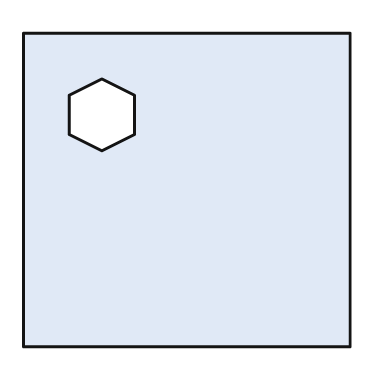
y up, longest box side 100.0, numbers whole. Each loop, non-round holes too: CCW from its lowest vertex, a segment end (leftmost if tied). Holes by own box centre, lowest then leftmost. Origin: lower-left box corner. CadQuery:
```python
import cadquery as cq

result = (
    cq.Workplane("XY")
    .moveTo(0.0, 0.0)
    .lineTo(100.0, 0.0)
    .lineTo(100.0, 96.0)
    .lineTo(0.0, 96.0)
    .close()
    .moveTo(24.0, 60.0)
    .lineTo(34.0, 65.0)
    .lineTo(34.0, 77.0)
    .lineTo(24.0, 82.0)
    .lineTo(14.0, 77.0)
    .lineTo(14.0, 65.0)
    .close()
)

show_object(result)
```